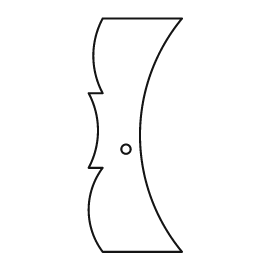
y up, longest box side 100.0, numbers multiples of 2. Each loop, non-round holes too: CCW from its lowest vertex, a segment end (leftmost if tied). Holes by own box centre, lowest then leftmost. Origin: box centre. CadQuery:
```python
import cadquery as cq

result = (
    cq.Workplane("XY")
    .moveTo(-14.0, -50.0)
    .lineTo(20.0, -50.0)
    .threePointArc((2.0, 0.0), (20.0, 50.0))
    .lineTo(-14.0, 50.0)
    .threePointArc((-18.0, 34.0), (-14.0, 18.0))
    .lineTo(-20.0, 18.0)
    .threePointArc((-16.0, 2.0), (-20.0, -14.0))
    .lineTo(-14.0, -14.0)
    .threePointArc((-20.0, -32.0), (-14.0, -50.0))
    .close()
    .moveTo(-4.0, -6.0)
    .circle(2.0)
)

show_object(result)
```